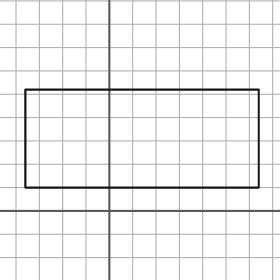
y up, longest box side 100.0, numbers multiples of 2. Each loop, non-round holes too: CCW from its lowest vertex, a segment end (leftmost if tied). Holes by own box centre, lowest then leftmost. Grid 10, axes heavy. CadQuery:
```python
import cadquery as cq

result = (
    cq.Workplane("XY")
    .moveTo(-36.0, 10.0)
    .lineTo(64.0, 10.0)
    .lineTo(64.0, 52.0)
    .lineTo(-36.0, 52.0)
    .close()
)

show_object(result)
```